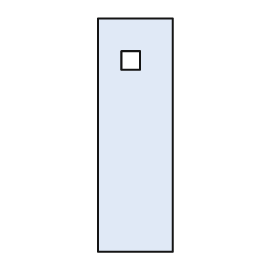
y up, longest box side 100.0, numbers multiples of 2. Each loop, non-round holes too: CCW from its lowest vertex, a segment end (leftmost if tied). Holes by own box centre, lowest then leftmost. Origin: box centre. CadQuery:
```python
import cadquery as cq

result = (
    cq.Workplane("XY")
    .moveTo(-16.0, -50.0)
    .lineTo(16.0, -50.0)
    .lineTo(16.0, 50.0)
    .lineTo(-16.0, 50.0)
    .close()
    .moveTo(-6.0, 28.0)
    .lineTo(2.0, 28.0)
    .lineTo(2.0, 36.0)
    .lineTo(-6.0, 36.0)
    .close()
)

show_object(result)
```